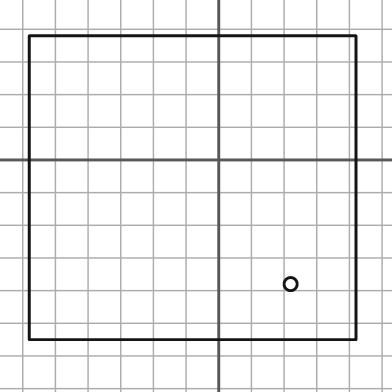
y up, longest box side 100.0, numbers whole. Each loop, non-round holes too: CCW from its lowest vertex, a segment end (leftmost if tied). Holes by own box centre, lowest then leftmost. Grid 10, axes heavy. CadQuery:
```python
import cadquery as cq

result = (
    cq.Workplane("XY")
    .moveTo(-58.0, -55.0)
    .lineTo(42.0, -55.0)
    .lineTo(42.0, 38.0)
    .lineTo(-58.0, 38.0)
    .close()
    .moveTo(22.0, -38.0)
    .circle(2.0)
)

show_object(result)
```